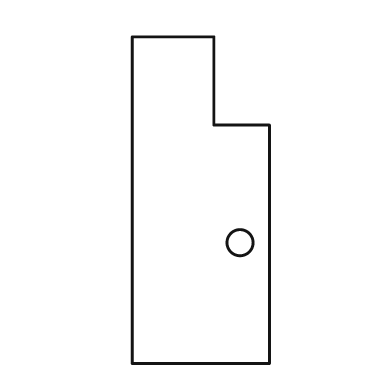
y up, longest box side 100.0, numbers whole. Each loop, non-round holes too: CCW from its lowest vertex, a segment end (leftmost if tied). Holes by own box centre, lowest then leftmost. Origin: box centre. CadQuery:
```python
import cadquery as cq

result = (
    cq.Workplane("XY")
    .moveTo(-21.0, -50.0)
    .lineTo(21.0, -50.0)
    .lineTo(21.0, 23.0)
    .lineTo(4.0, 23.0)
    .lineTo(4.0, 50.0)
    .lineTo(-21.0, 50.0)
    .close()
    .moveTo(12.0, -13.0)
    .circle(4.0)
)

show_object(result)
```